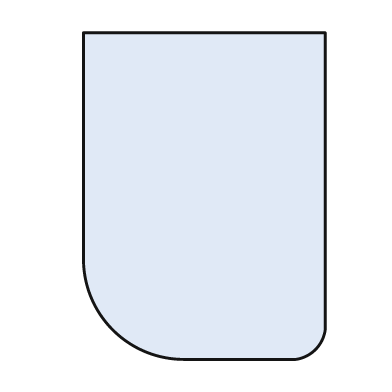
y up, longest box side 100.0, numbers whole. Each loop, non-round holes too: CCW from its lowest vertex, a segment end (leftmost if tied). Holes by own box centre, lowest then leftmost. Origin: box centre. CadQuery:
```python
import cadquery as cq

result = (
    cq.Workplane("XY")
    .moveTo(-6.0, -50.0)
    .lineTo(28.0, -50.0)
    .threePointArc((34.0, -47.0), (37.0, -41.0))
    .lineTo(37.0, 50.0)
    .lineTo(-37.0, 50.0)
    .lineTo(-37.0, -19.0)
    .threePointArc((-28.0, -41.0), (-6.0, -50.0))
    .close()
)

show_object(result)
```